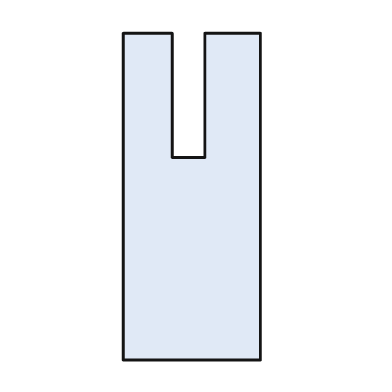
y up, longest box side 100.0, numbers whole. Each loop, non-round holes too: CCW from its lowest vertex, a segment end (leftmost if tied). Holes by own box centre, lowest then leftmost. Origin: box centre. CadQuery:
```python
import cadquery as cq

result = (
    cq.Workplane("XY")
    .moveTo(-21.0, -50.0)
    .lineTo(21.0, -50.0)
    .lineTo(21.0, 50.0)
    .lineTo(4.0, 50.0)
    .lineTo(4.0, 12.0)
    .lineTo(-6.0, 12.0)
    .lineTo(-6.0, 50.0)
    .lineTo(-21.0, 50.0)
    .close()
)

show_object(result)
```